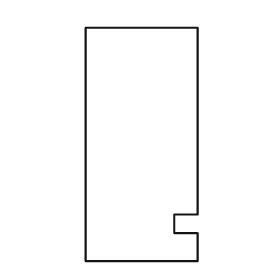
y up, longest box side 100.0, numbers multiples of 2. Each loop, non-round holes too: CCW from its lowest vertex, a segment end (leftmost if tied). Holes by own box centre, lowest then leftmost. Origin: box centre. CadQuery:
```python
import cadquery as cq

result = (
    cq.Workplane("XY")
    .moveTo(-24.0, -50.0)
    .lineTo(24.0, -50.0)
    .lineTo(24.0, -38.0)
    .lineTo(14.0, -38.0)
    .lineTo(14.0, -30.0)
    .lineTo(24.0, -30.0)
    .lineTo(24.0, 50.0)
    .lineTo(-24.0, 50.0)
    .close()
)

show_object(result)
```